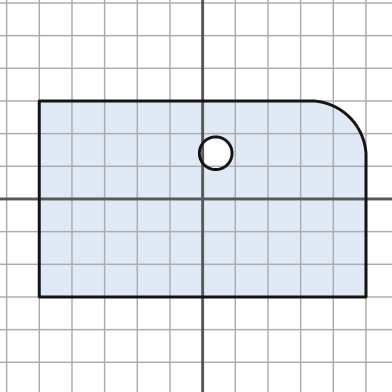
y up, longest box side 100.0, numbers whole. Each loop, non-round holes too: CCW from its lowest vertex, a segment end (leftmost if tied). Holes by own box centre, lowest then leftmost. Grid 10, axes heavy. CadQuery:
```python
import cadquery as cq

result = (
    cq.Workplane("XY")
    .moveTo(-50.0, -30.0)
    .lineTo(50.0, -30.0)
    .lineTo(50.0, 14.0)
    .threePointArc((45.0, 25.0), (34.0, 30.0))
    .lineTo(-50.0, 30.0)
    .close()
    .moveTo(4.0, 14.0)
    .circle(5.0)
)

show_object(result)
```